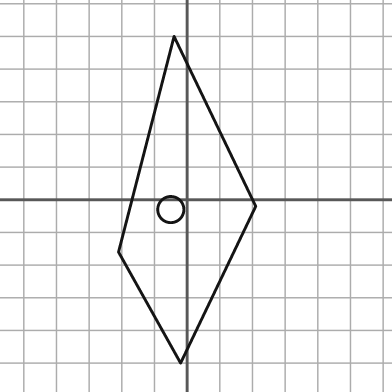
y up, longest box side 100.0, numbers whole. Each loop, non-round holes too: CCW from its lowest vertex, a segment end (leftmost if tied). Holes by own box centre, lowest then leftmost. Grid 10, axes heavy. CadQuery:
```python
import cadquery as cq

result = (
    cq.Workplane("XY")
    .moveTo(-2.0, -50.0)
    .lineTo(21.0, -2.0)
    .lineTo(-4.0, 50.0)
    .lineTo(-21.0, -16.0)
    .close()
    .moveTo(-5.0, -3.0)
    .circle(4.0)
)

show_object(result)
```